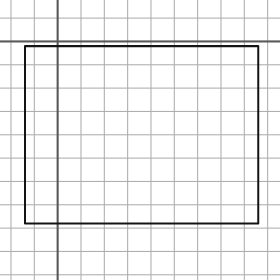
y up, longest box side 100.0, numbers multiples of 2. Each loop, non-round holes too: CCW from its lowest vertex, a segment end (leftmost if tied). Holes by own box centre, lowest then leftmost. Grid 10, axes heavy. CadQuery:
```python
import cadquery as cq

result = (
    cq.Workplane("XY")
    .moveTo(-14.0, -78.0)
    .lineTo(86.0, -78.0)
    .lineTo(86.0, -2.0)
    .lineTo(-14.0, -2.0)
    .close()
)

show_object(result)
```